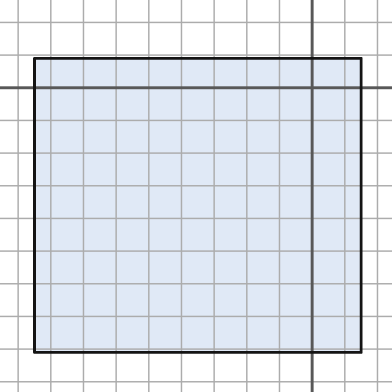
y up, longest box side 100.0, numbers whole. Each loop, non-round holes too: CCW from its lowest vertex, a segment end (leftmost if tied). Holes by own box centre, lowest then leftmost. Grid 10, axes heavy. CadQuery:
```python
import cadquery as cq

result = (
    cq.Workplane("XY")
    .moveTo(-85.0, -81.0)
    .lineTo(15.0, -81.0)
    .lineTo(15.0, 9.0)
    .lineTo(-85.0, 9.0)
    .close()
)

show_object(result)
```